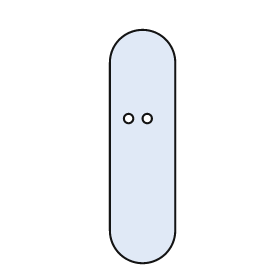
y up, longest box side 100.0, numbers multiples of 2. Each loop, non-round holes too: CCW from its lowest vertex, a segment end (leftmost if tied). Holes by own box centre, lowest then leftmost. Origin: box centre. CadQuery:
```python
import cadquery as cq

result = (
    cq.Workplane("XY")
    .moveTo(-14.0, -36.0)
    .threePointArc((0.0, -50.0), (14.0, -36.0))
    .lineTo(14.0, 36.0)
    .threePointArc((0.0, 50.0), (-14.0, 36.0))
    .close()
    .moveTo(-6.0, 12.0)
    .circle(2.0)
    .moveTo(2.0, 12.0)
    .circle(2.0)
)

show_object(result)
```